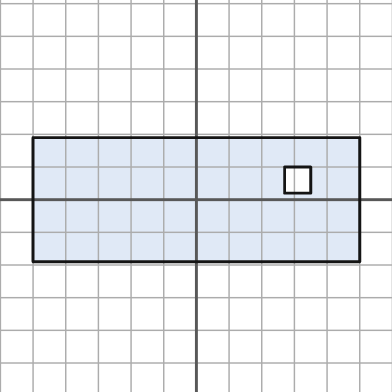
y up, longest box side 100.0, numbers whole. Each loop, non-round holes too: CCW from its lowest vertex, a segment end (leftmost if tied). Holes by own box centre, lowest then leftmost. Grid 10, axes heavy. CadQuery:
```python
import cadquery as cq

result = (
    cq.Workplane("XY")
    .moveTo(-50.0, -19.0)
    .lineTo(50.0, -19.0)
    .lineTo(50.0, 19.0)
    .lineTo(-50.0, 19.0)
    .close()
    .moveTo(27.0, 2.0)
    .lineTo(35.0, 2.0)
    .lineTo(35.0, 10.0)
    .lineTo(27.0, 10.0)
    .close()
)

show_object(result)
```